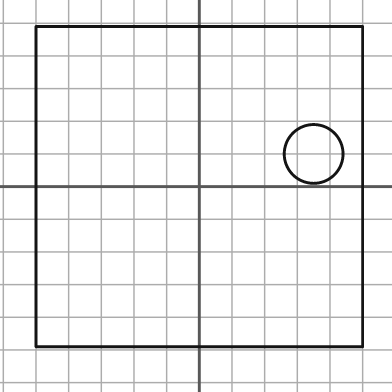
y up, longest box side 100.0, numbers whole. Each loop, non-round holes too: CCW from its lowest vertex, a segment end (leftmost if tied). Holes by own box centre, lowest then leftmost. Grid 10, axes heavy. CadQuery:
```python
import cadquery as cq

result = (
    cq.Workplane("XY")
    .moveTo(-50.0, -49.0)
    .lineTo(50.0, -49.0)
    .lineTo(50.0, 49.0)
    .lineTo(-50.0, 49.0)
    .close()
    .moveTo(35.0, 10.0)
    .circle(9.0)
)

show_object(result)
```